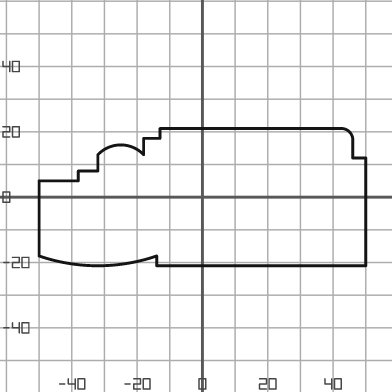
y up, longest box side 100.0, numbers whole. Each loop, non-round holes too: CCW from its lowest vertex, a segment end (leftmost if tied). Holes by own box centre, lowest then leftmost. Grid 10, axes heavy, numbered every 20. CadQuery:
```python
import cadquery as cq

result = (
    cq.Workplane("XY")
    .moveTo(-14.0, -21.0)
    .lineTo(50.0, -21.0)
    .lineTo(50.0, 12.0)
    .lineTo(46.0, 12.0)
    .lineTo(46.0, 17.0)
    .threePointArc((45.0, 20.0), (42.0, 21.0))
    .lineTo(-13.0, 21.0)
    .lineTo(-13.0, 18.0)
    .lineTo(-18.0, 18.0)
    .lineTo(-18.0, 13.0)
    .threePointArc((-25.0, 16.0), (-32.0, 13.0))
    .lineTo(-32.0, 8.0)
    .lineTo(-38.0, 8.0)
    .lineTo(-38.0, 5.0)
    .lineTo(-50.0, 5.0)
    .lineTo(-50.0, -18.0)
    .threePointArc((-32.0, -21.0), (-14.0, -18.0))
    .close()
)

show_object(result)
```